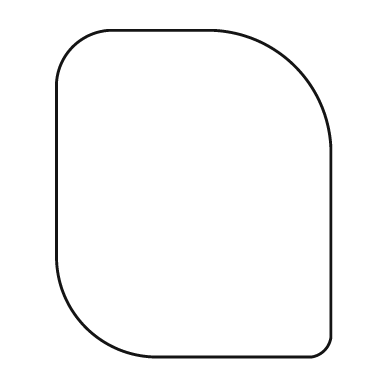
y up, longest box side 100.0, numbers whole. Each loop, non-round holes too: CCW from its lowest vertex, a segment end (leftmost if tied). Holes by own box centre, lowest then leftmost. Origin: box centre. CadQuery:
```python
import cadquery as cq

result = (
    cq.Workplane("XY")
    .moveTo(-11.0, -50.0)
    .lineTo(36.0, -50.0)
    .threePointArc((40.0, -48.0), (42.0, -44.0))
    .lineTo(42.0, 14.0)
    .threePointArc((31.0, 39.0), (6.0, 50.0))
    .lineTo(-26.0, 50.0)
    .threePointArc((-37.0, 45.0), (-42.0, 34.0))
    .lineTo(-42.0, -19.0)
    .threePointArc((-33.0, -41.0), (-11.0, -50.0))
    .close()
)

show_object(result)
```